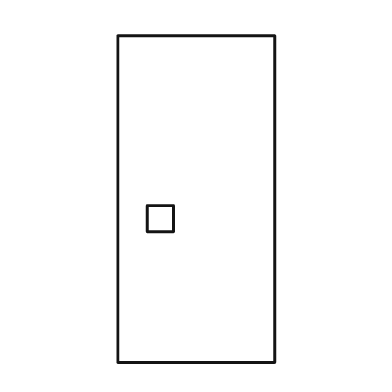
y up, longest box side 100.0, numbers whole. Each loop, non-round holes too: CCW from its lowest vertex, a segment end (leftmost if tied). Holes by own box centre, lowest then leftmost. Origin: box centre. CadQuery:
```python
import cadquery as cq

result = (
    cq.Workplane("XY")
    .moveTo(-24.0, -50.0)
    .lineTo(24.0, -50.0)
    .lineTo(24.0, 50.0)
    .lineTo(-24.0, 50.0)
    .close()
    .moveTo(-15.0, -10.0)
    .lineTo(-7.0, -10.0)
    .lineTo(-7.0, -2.0)
    .lineTo(-15.0, -2.0)
    .close()
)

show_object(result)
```